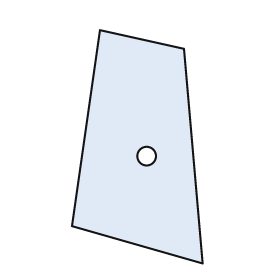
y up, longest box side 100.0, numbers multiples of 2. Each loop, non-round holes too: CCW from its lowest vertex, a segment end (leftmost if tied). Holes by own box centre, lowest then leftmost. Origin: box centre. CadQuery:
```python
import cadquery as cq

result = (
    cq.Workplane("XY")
    .moveTo(28.0, -50.0)
    .lineTo(20.0, 42.0)
    .lineTo(-16.0, 50.0)
    .lineTo(-28.0, -34.0)
    .close()
    .moveTo(4.0, -4.0)
    .circle(4.0)
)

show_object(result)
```